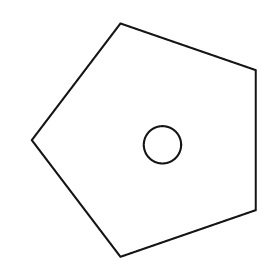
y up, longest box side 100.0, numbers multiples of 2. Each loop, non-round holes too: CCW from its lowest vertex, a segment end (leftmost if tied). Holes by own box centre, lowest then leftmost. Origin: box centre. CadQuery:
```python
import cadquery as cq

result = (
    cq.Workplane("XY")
    .moveTo(-10.0, -50.0)
    .lineTo(48.0, -30.0)
    .lineTo(48.0, 30.0)
    .lineTo(-10.0, 50.0)
    .lineTo(-48.0, 0.0)
    .close()
    .moveTo(8.0, -2.0)
    .circle(8.0)
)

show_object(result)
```